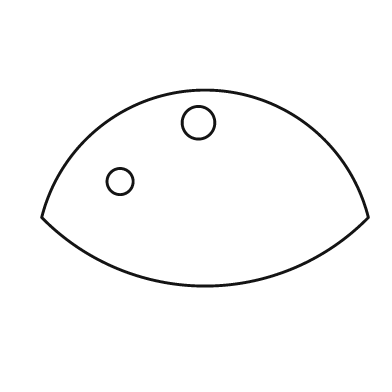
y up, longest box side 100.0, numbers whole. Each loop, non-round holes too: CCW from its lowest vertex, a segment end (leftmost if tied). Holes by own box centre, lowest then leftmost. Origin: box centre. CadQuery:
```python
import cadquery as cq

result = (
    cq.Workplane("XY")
    .moveTo(-50.0, -9.0)
    .threePointArc((0.0, -30.0), (50.0, -9.0))
    .threePointArc((0.0, 30.0), (-50.0, -9.0))
    .close()
    .moveTo(-26.0, 2.0)
    .circle(4.0)
    .moveTo(-2.0, 20.0)
    .circle(5.0)
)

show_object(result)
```